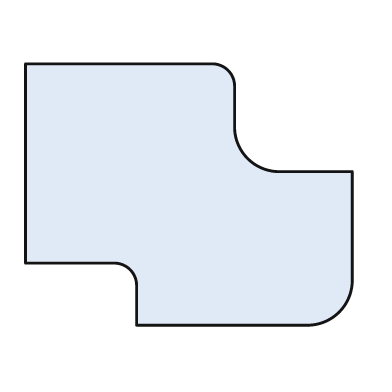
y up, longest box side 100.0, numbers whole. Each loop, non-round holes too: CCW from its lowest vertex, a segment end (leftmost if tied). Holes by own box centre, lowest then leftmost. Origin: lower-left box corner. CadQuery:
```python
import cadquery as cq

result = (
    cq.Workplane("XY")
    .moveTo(34.0, 0.0)
    .lineTo(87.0, 0.0)
    .threePointArc((96.0, 4.0), (100.0, 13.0))
    .lineTo(100.0, 47.0)
    .lineTo(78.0, 47.0)
    .threePointArc((68.0, 51.0), (64.0, 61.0))
    .lineTo(64.0, 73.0)
    .threePointArc((62.0, 78.0), (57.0, 80.0))
    .lineTo(0.0, 80.0)
    .lineTo(0.0, 19.0)
    .lineTo(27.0, 19.0)
    .threePointArc((32.0, 17.0), (34.0, 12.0))
    .close()
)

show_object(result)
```